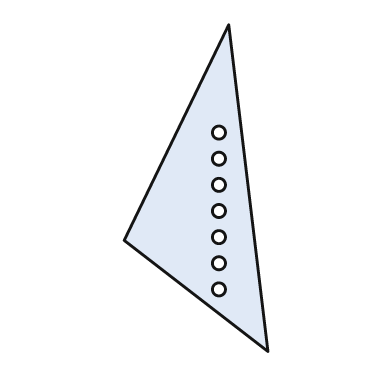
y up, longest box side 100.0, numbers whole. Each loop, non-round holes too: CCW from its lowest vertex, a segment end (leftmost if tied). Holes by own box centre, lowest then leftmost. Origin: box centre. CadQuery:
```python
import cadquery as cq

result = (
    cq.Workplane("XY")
    .moveTo(22.0, -50.0)
    .lineTo(10.0, 50.0)
    .lineTo(-22.0, -16.0)
    .close()
    .moveTo(7.0, -31.0)
    .circle(2.0)
    .moveTo(7.0, -23.0)
    .circle(2.0)
    .moveTo(7.0, -15.0)
    .circle(2.0)
    .moveTo(7.0, -7.0)
    .circle(2.0)
    .moveTo(7.0, 1.0)
    .circle(2.0)
    .moveTo(7.0, 9.0)
    .circle(2.0)
    .moveTo(7.0, 17.0)
    .circle(2.0)
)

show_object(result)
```